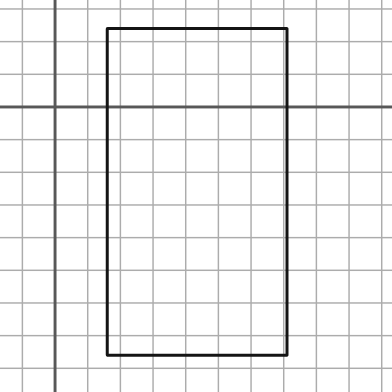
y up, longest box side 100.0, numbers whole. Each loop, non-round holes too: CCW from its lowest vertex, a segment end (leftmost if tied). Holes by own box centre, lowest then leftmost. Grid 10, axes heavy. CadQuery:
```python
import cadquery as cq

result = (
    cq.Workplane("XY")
    .moveTo(16.0, -76.0)
    .lineTo(71.0, -76.0)
    .lineTo(71.0, 24.0)
    .lineTo(16.0, 24.0)
    .close()
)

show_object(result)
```